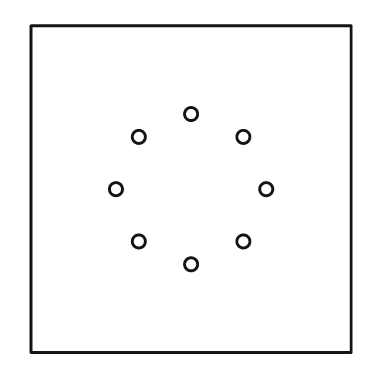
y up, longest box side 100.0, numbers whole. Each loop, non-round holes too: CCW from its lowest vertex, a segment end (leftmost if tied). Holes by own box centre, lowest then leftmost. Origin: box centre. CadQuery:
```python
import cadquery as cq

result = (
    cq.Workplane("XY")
    .moveTo(-49.0, -50.0)
    .lineTo(49.0, -50.0)
    .lineTo(49.0, 50.0)
    .lineTo(-49.0, 50.0)
    .close()
    .moveTo(0.0, -23.0)
    .circle(2.0)
    .moveTo(-16.0, -16.0)
    .circle(2.0)
    .moveTo(16.0, -16.0)
    .circle(2.0)
    .moveTo(-23.0, 0.0)
    .circle(2.0)
    .moveTo(23.0, 0.0)
    .circle(2.0)
    .moveTo(-16.0, 16.0)
    .circle(2.0)
    .moveTo(16.0, 16.0)
    .circle(2.0)
    .moveTo(0.0, 23.0)
    .circle(2.0)
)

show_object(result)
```